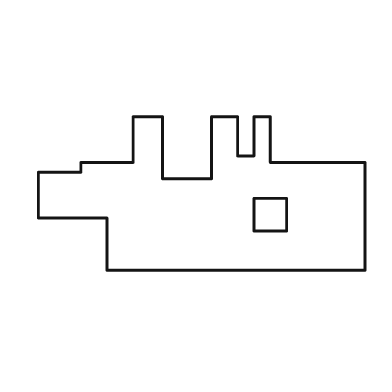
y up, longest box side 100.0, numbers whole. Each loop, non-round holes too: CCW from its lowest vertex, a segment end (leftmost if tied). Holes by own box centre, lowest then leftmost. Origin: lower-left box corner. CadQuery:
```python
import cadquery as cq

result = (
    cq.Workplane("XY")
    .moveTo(21.0, 0.0)
    .lineTo(100.0, 0.0)
    .lineTo(100.0, 33.0)
    .lineTo(71.0, 33.0)
    .lineTo(71.0, 47.0)
    .lineTo(66.0, 47.0)
    .lineTo(66.0, 35.0)
    .lineTo(61.0, 35.0)
    .lineTo(61.0, 47.0)
    .lineTo(53.0, 47.0)
    .lineTo(53.0, 28.0)
    .lineTo(38.0, 28.0)
    .lineTo(38.0, 47.0)
    .lineTo(29.0, 47.0)
    .lineTo(29.0, 33.0)
    .lineTo(13.0, 33.0)
    .lineTo(13.0, 30.0)
    .lineTo(0.0, 30.0)
    .lineTo(0.0, 16.0)
    .lineTo(21.0, 16.0)
    .close()
    .moveTo(66.0, 12.0)
    .lineTo(76.0, 12.0)
    .lineTo(76.0, 22.0)
    .lineTo(66.0, 22.0)
    .close()
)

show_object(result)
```